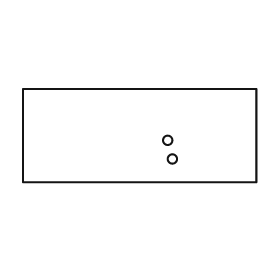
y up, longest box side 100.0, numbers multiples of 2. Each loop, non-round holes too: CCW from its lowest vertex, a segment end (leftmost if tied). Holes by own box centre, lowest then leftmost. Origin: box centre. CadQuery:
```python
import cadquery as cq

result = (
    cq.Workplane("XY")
    .moveTo(-50.0, -20.0)
    .lineTo(50.0, -20.0)
    .lineTo(50.0, 20.0)
    .lineTo(-50.0, 20.0)
    .close()
    .moveTo(14.0, -10.0)
    .circle(2.0)
    .moveTo(12.0, -2.0)
    .circle(2.0)
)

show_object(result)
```